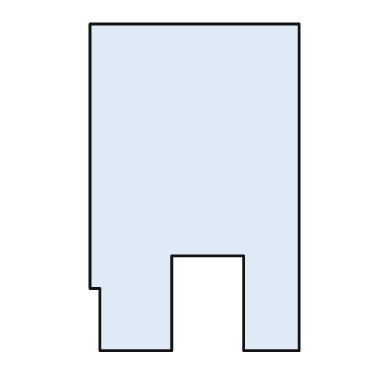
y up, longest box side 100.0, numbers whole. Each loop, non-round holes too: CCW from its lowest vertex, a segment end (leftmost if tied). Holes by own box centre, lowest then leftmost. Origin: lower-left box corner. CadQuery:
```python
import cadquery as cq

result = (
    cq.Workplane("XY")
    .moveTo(3.0, 0.0)
    .lineTo(25.0, 0.0)
    .lineTo(25.0, 29.0)
    .lineTo(47.0, 29.0)
    .lineTo(47.0, 0.0)
    .lineTo(64.0, 0.0)
    .lineTo(64.0, 100.0)
    .lineTo(0.0, 100.0)
    .lineTo(0.0, 19.0)
    .lineTo(3.0, 19.0)
    .close()
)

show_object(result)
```